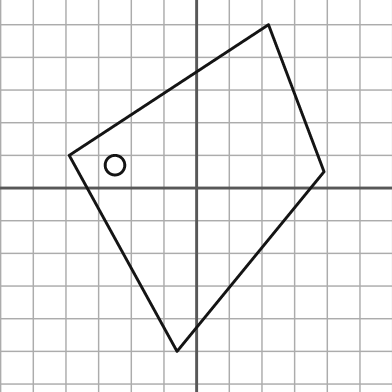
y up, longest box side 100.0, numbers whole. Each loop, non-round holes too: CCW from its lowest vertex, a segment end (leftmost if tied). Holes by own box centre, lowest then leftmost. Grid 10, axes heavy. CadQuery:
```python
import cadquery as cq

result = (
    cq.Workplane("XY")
    .moveTo(-6.0, -50.0)
    .lineTo(39.0, 5.0)
    .lineTo(22.0, 50.0)
    .lineTo(-39.0, 10.0)
    .close()
    .moveTo(-25.0, 7.0)
    .circle(3.0)
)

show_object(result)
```